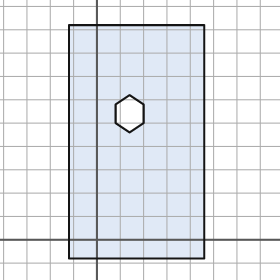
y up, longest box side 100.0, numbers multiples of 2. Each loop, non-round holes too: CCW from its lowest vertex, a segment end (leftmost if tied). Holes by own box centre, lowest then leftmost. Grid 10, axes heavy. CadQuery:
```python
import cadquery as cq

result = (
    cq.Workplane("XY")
    .moveTo(-12.0, -8.0)
    .lineTo(46.0, -8.0)
    .lineTo(46.0, 92.0)
    .lineTo(-12.0, 92.0)
    .close()
    .moveTo(14.0, 46.0)
    .lineTo(20.0, 50.0)
    .lineTo(20.0, 58.0)
    .lineTo(14.0, 62.0)
    .lineTo(8.0, 58.0)
    .lineTo(8.0, 50.0)
    .close()
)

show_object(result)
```